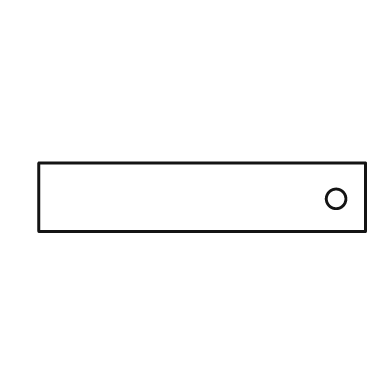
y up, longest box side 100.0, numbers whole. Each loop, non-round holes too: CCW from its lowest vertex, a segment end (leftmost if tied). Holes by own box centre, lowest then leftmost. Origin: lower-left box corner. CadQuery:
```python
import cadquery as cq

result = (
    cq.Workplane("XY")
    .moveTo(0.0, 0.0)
    .lineTo(100.0, 0.0)
    .lineTo(100.0, 21.0)
    .lineTo(0.0, 21.0)
    .close()
    .moveTo(91.0, 10.0)
    .circle(3.0)
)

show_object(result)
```